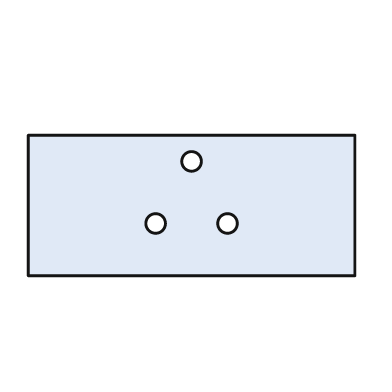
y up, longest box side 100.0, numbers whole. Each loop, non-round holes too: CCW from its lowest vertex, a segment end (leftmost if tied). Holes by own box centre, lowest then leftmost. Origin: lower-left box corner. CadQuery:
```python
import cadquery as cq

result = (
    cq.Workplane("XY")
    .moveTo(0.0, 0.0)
    .lineTo(100.0, 0.0)
    .lineTo(100.0, 43.0)
    .lineTo(0.0, 43.0)
    .close()
    .moveTo(39.0, 16.0)
    .circle(3.0)
    .moveTo(61.0, 16.0)
    .circle(3.0)
    .moveTo(50.0, 35.0)
    .circle(3.0)
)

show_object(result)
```